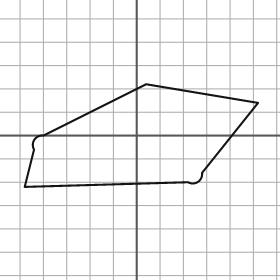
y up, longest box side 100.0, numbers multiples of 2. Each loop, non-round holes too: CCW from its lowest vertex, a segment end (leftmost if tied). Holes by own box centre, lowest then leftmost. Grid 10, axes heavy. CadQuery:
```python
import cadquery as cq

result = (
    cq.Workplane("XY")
    .moveTo(-48.0, -22.0)
    .lineTo(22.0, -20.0)
    .threePointArc((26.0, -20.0), (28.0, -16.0))
    .lineTo(52.0, 14.0)
    .lineTo(4.0, 22.0)
    .lineTo(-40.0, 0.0)
    .threePointArc((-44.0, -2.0), (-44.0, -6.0))
    .close()
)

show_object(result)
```